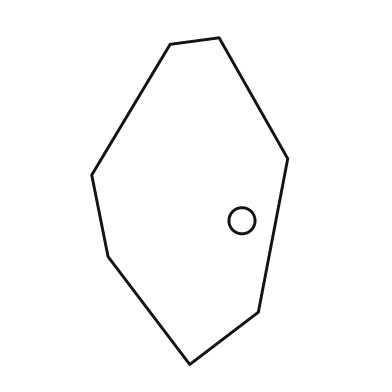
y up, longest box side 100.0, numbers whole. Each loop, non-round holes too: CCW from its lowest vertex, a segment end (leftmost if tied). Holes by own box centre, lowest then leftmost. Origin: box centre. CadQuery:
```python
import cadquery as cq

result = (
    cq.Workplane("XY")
    .moveTo(0.0, -50.0)
    .lineTo(21.0, -34.0)
    .lineTo(30.0, 13.0)
    .lineTo(9.0, 50.0)
    .lineTo(-6.0, 48.0)
    .lineTo(-30.0, 8.0)
    .lineTo(-25.0, -17.0)
    .close()
    .moveTo(16.0, -6.0)
    .circle(4.0)
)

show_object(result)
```